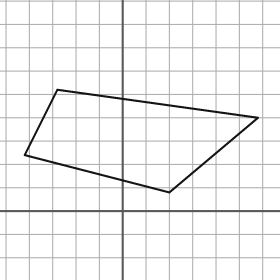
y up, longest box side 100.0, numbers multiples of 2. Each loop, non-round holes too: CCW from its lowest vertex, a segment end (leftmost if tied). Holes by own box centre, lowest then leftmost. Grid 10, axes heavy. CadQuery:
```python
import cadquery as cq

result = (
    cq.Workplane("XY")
    .moveTo(20.0, 8.0)
    .lineTo(58.0, 40.0)
    .lineTo(-28.0, 52.0)
    .lineTo(-42.0, 24.0)
    .close()
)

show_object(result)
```